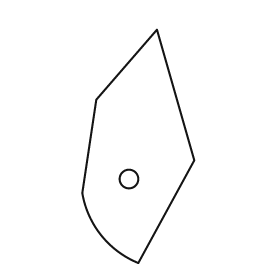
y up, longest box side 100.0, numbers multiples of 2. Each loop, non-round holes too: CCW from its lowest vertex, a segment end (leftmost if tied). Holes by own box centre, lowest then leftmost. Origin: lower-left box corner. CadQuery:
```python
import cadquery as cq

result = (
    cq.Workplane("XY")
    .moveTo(24.0, 0.0)
    .lineTo(48.0, 44.0)
    .lineTo(32.0, 100.0)
    .lineTo(6.0, 70.0)
    .lineTo(0.0, 30.0)
    .threePointArc((8.0, 12.0), (24.0, 0.0))
    .close()
    .moveTo(20.0, 36.0)
    .circle(4.0)
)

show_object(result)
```